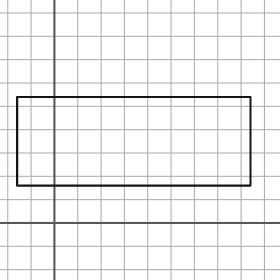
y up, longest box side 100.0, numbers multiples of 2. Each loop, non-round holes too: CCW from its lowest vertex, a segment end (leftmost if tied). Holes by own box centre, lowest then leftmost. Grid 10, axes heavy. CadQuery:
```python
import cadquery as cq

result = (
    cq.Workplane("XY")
    .moveTo(-16.0, 16.0)
    .lineTo(84.0, 16.0)
    .lineTo(84.0, 54.0)
    .lineTo(-16.0, 54.0)
    .close()
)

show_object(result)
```